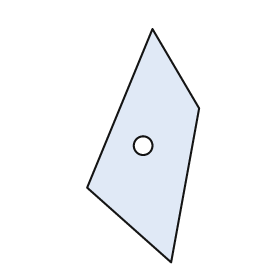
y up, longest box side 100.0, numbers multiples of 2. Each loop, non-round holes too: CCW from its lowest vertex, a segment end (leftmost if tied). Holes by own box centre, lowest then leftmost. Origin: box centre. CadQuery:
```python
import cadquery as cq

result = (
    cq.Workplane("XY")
    .moveTo(12.0, -50.0)
    .lineTo(24.0, 16.0)
    .lineTo(4.0, 50.0)
    .lineTo(-24.0, -18.0)
    .close()
    .moveTo(0.0, 0.0)
    .circle(4.0)
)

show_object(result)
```